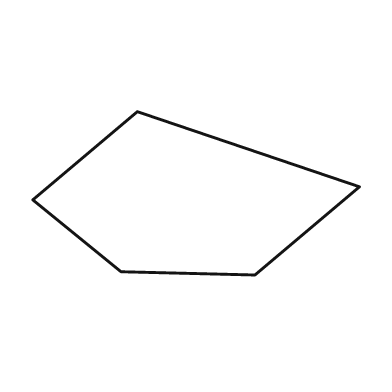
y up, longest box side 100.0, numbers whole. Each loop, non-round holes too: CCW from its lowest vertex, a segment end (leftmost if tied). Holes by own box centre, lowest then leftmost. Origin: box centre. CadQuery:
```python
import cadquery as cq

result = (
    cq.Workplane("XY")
    .moveTo(18.0, -25.0)
    .lineTo(50.0, 2.0)
    .lineTo(-18.0, 25.0)
    .lineTo(-50.0, -2.0)
    .lineTo(-23.0, -24.0)
    .close()
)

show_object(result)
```